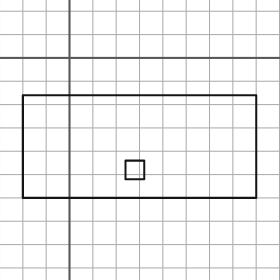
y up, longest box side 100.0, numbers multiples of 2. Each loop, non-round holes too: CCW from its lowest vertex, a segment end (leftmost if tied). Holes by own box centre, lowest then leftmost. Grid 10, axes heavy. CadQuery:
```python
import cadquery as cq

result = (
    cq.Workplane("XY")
    .moveTo(-20.0, -60.0)
    .lineTo(80.0, -60.0)
    .lineTo(80.0, -16.0)
    .lineTo(-20.0, -16.0)
    .close()
    .moveTo(24.0, -52.0)
    .lineTo(32.0, -52.0)
    .lineTo(32.0, -44.0)
    .lineTo(24.0, -44.0)
    .close()
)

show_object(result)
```